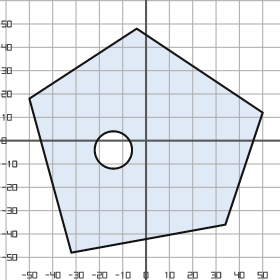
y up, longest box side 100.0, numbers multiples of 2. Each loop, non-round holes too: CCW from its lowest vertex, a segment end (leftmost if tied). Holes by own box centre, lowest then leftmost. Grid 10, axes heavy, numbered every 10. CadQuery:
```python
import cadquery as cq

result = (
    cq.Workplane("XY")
    .moveTo(-32.0, -48.0)
    .lineTo(34.0, -36.0)
    .lineTo(50.0, 12.0)
    .lineTo(-4.0, 48.0)
    .lineTo(-50.0, 18.0)
    .close()
    .moveTo(-14.0, -4.0)
    .circle(8.0)
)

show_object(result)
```